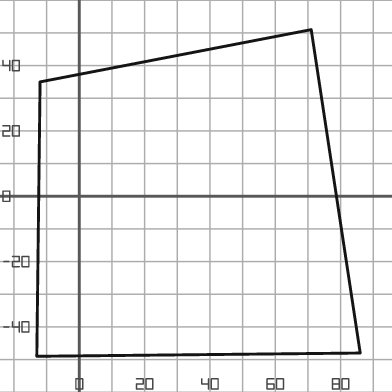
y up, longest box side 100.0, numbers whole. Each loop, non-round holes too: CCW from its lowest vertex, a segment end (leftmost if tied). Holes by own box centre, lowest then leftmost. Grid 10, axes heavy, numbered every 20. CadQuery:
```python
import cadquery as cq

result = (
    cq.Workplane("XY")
    .moveTo(-13.0, -49.0)
    .lineTo(86.0, -48.0)
    .lineTo(71.0, 51.0)
    .lineTo(-12.0, 35.0)
    .close()
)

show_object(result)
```